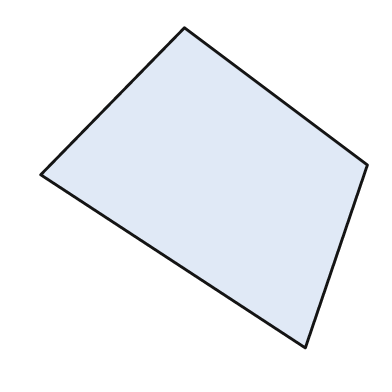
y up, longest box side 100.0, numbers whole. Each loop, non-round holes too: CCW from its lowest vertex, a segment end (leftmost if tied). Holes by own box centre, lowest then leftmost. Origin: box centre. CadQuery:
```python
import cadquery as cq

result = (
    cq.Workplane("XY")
    .moveTo(31.0, -49.0)
    .lineTo(50.0, 7.0)
    .lineTo(-6.0, 49.0)
    .lineTo(-50.0, 4.0)
    .close()
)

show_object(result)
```